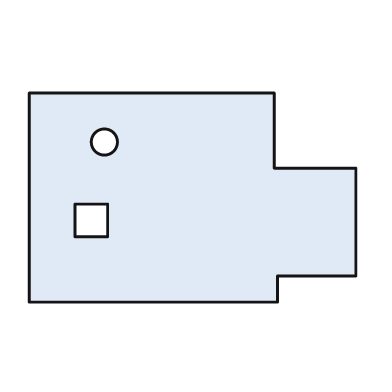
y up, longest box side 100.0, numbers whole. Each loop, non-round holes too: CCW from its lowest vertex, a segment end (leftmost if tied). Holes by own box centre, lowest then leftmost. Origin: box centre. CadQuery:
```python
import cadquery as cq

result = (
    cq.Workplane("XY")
    .moveTo(-50.0, -32.0)
    .lineTo(26.0, -32.0)
    .lineTo(26.0, -24.0)
    .lineTo(50.0, -24.0)
    .lineTo(50.0, 9.0)
    .lineTo(25.0, 9.0)
    .lineTo(25.0, 32.0)
    .lineTo(-50.0, 32.0)
    .close()
    .moveTo(-36.0, -12.0)
    .lineTo(-26.0, -12.0)
    .lineTo(-26.0, -2.0)
    .lineTo(-36.0, -2.0)
    .close()
    .moveTo(-27.0, 17.0)
    .circle(4.0)
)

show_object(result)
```